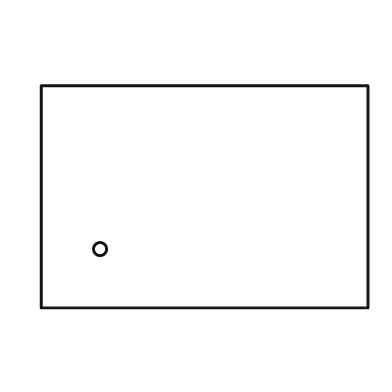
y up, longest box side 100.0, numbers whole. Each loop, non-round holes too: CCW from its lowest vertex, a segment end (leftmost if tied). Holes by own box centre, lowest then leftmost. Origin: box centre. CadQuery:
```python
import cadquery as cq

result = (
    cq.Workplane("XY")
    .moveTo(-50.0, -34.0)
    .lineTo(50.0, -34.0)
    .lineTo(50.0, 34.0)
    .lineTo(-50.0, 34.0)
    .close()
    .moveTo(-32.0, -16.0)
    .circle(2.0)
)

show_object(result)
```